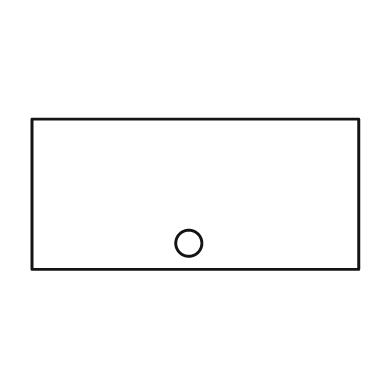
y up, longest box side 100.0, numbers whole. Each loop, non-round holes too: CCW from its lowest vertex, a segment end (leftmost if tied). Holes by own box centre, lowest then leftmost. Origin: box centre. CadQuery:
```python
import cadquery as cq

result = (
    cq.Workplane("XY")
    .moveTo(-50.0, -23.0)
    .lineTo(50.0, -23.0)
    .lineTo(50.0, 23.0)
    .lineTo(-50.0, 23.0)
    .close()
    .moveTo(-2.0, -15.0)
    .circle(4.0)
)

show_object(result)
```